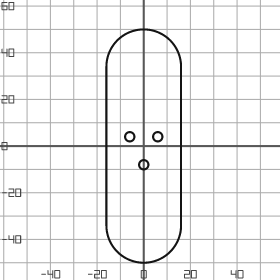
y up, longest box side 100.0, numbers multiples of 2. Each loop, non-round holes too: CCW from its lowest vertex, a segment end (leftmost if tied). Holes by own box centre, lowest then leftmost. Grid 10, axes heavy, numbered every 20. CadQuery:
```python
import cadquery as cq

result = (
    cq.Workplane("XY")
    .moveTo(-16.0, -34.0)
    .threePointArc((0.0, -50.0), (16.0, -34.0))
    .lineTo(16.0, 34.0)
    .threePointArc((0.0, 50.0), (-16.0, 34.0))
    .close()
    .moveTo(0.0, -8.0)
    .circle(2.0)
    .moveTo(-6.0, 4.0)
    .circle(2.0)
    .moveTo(6.0, 4.0)
    .circle(2.0)
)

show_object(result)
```